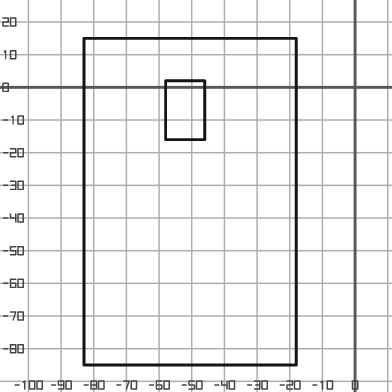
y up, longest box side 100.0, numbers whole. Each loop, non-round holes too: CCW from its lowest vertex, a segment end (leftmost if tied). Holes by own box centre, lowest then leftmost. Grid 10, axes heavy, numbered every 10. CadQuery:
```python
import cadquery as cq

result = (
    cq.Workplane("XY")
    .moveTo(-83.0, -85.0)
    .lineTo(-18.0, -85.0)
    .lineTo(-18.0, 15.0)
    .lineTo(-83.0, 15.0)
    .close()
    .moveTo(-58.0, -16.0)
    .lineTo(-46.0, -16.0)
    .lineTo(-46.0, 2.0)
    .lineTo(-58.0, 2.0)
    .close()
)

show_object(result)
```